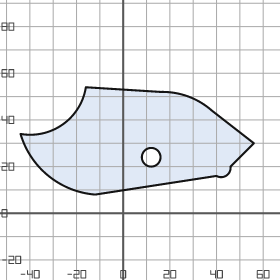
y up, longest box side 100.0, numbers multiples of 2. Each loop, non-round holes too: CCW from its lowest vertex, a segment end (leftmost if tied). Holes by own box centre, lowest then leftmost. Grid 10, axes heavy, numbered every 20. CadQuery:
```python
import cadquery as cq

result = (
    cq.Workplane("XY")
    .moveTo(-12.0, 8.0)
    .lineTo(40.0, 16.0)
    .threePointArc((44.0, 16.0), (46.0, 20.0))
    .lineTo(56.0, 30.0)
    .lineTo(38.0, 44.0)
    .threePointArc((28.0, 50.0), (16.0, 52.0))
    .lineTo(-16.0, 54.0)
    .threePointArc((-26.0, 38.0), (-44.0, 34.0))
    .threePointArc((-32.0, 16.0), (-12.0, 8.0))
    .close()
    .moveTo(12.0, 24.0)
    .circle(4.0)
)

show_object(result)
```